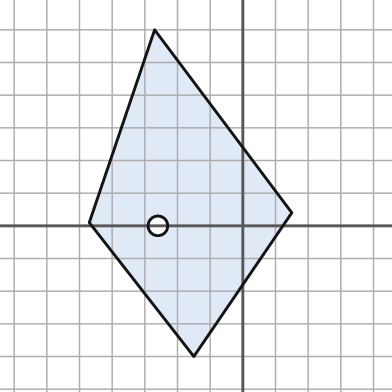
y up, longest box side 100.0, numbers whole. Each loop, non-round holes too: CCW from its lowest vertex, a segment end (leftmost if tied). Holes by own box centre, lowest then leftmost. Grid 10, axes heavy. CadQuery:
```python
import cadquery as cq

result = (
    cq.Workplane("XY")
    .moveTo(-15.0, -40.0)
    .lineTo(15.0, 4.0)
    .lineTo(-27.0, 60.0)
    .lineTo(-47.0, 1.0)
    .close()
    .moveTo(-26.0, 0.0)
    .circle(3.0)
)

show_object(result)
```